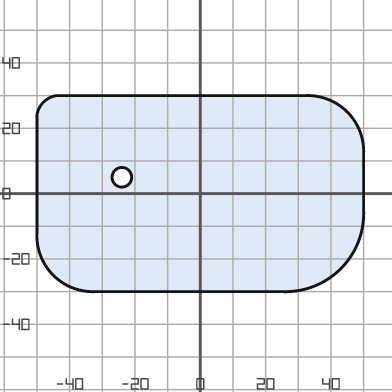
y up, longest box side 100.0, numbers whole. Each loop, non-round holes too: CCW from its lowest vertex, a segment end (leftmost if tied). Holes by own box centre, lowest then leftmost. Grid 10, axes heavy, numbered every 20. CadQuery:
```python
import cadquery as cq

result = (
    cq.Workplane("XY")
    .moveTo(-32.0, -30.0)
    .lineTo(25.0, -30.0)
    .threePointArc((43.0, -23.0), (50.0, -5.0))
    .lineTo(50.0, 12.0)
    .threePointArc((45.0, 25.0), (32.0, 30.0))
    .lineTo(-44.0, 30.0)
    .threePointArc((-48.0, 28.0), (-50.0, 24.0))
    .lineTo(-50.0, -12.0)
    .threePointArc((-45.0, -25.0), (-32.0, -30.0))
    .close()
    .moveTo(-24.0, 5.0)
    .circle(3.0)
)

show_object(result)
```